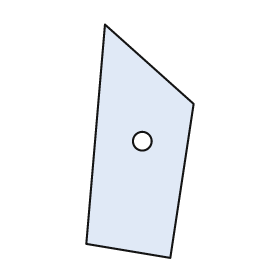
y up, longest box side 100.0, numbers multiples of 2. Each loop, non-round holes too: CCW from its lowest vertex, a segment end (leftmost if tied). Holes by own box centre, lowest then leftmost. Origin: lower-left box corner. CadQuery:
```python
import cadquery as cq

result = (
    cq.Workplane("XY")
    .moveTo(36.0, 0.0)
    .lineTo(46.0, 66.0)
    .lineTo(8.0, 100.0)
    .lineTo(0.0, 6.0)
    .close()
    .moveTo(24.0, 50.0)
    .circle(4.0)
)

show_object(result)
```